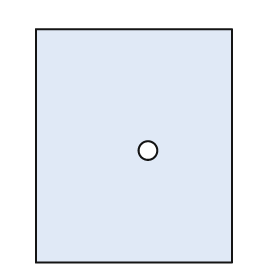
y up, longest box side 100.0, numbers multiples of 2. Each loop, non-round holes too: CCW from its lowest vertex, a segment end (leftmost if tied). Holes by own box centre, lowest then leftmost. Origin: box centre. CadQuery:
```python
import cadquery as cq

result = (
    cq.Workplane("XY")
    .moveTo(-42.0, -50.0)
    .lineTo(42.0, -50.0)
    .lineTo(42.0, 50.0)
    .lineTo(-42.0, 50.0)
    .close()
    .moveTo(6.0, -2.0)
    .circle(4.0)
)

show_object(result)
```